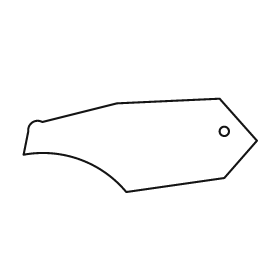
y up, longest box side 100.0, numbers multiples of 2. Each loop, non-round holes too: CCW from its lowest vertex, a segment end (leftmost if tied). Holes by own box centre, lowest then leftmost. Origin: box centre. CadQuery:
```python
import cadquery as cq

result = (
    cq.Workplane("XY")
    .moveTo(-6.0, -20.0)
    .lineTo(36.0, -14.0)
    .lineTo(50.0, 2.0)
    .lineTo(34.0, 20.0)
    .lineTo(-10.0, 18.0)
    .lineTo(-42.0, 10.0)
    .threePointArc((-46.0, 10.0), (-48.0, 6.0))
    .lineTo(-50.0, -4.0)
    .threePointArc((-26.0, -6.0), (-6.0, -20.0))
    .close()
    .moveTo(36.0, 6.0)
    .circle(2.0)
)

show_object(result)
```